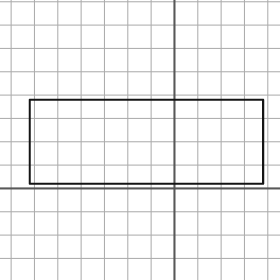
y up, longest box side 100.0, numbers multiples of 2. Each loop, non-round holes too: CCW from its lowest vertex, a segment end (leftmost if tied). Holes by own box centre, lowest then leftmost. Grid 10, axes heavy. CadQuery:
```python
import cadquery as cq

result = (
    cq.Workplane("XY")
    .moveTo(-62.0, 2.0)
    .lineTo(38.0, 2.0)
    .lineTo(38.0, 38.0)
    .lineTo(-62.0, 38.0)
    .close()
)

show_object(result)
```